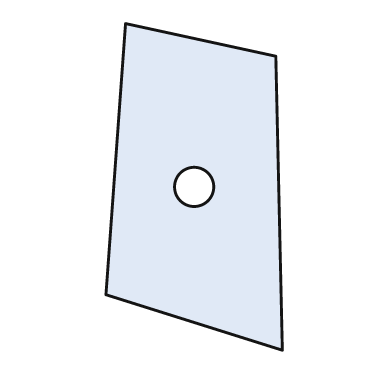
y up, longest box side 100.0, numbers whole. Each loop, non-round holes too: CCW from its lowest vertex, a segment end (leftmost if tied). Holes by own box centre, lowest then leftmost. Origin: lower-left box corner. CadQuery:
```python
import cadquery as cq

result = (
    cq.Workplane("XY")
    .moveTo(54.0, 0.0)
    .lineTo(52.0, 90.0)
    .lineTo(6.0, 100.0)
    .lineTo(0.0, 17.0)
    .close()
    .moveTo(27.0, 50.0)
    .circle(6.0)
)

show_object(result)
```